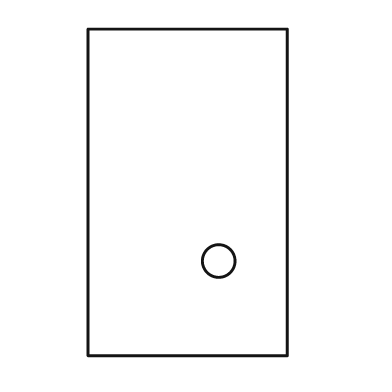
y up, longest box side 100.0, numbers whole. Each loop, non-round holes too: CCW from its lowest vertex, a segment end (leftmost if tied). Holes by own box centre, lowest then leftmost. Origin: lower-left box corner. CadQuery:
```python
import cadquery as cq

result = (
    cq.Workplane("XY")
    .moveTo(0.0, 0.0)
    .lineTo(61.0, 0.0)
    .lineTo(61.0, 100.0)
    .lineTo(0.0, 100.0)
    .close()
    .moveTo(40.0, 29.0)
    .circle(5.0)
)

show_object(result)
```